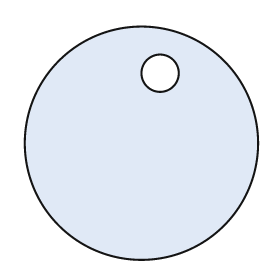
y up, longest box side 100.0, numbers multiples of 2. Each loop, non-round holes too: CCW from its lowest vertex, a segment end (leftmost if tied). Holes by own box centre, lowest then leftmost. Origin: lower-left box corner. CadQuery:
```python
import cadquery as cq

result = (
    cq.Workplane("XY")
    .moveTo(50.0, 50.0)
    .circle(50.0)
    .moveTo(58.0, 80.0)
    .circle(8.0)
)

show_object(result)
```